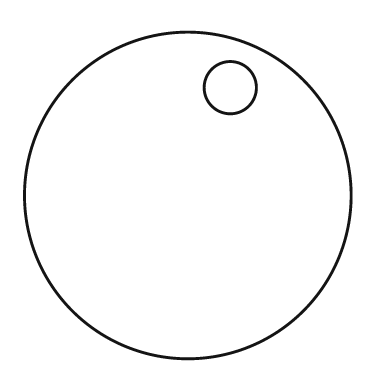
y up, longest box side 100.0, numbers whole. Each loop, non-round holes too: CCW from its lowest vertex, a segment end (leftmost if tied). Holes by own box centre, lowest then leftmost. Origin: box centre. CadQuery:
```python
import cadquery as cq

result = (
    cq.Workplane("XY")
    .moveTo(0.0, 0.0)
    .circle(50.0)
    .moveTo(13.0, 33.0)
    .circle(8.0)
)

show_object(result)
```